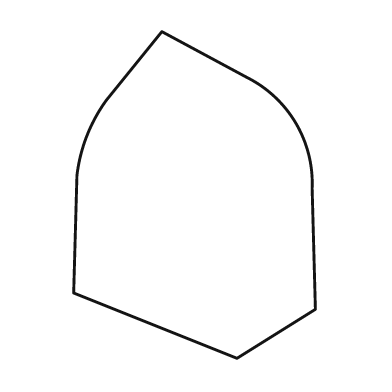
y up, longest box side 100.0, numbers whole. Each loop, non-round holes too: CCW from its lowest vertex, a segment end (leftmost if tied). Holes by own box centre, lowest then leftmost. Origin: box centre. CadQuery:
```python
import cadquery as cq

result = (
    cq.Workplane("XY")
    .moveTo(13.0, -50.0)
    .lineTo(37.0, -35.0)
    .lineTo(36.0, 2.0)
    .threePointArc((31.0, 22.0), (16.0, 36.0))
    .lineTo(-10.0, 50.0)
    .lineTo(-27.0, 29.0)
    .threePointArc((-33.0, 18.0), (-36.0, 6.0))
    .lineTo(-37.0, -30.0)
    .close()
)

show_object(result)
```